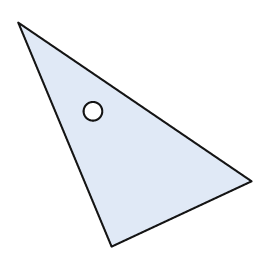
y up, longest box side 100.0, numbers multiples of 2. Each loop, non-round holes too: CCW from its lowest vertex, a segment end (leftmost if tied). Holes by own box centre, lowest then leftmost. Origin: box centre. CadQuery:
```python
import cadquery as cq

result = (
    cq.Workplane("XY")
    .moveTo(-10.0, -48.0)
    .lineTo(50.0, -20.0)
    .lineTo(-50.0, 48.0)
    .close()
    .moveTo(-18.0, 10.0)
    .circle(4.0)
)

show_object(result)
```